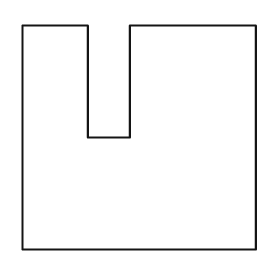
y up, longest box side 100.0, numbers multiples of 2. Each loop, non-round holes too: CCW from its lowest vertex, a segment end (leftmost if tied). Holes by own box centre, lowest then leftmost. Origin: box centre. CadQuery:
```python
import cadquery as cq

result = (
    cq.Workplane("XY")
    .moveTo(-50.0, -48.0)
    .lineTo(50.0, -48.0)
    .lineTo(50.0, 48.0)
    .lineTo(-4.0, 48.0)
    .lineTo(-4.0, 0.0)
    .lineTo(-22.0, 0.0)
    .lineTo(-22.0, 48.0)
    .lineTo(-50.0, 48.0)
    .close()
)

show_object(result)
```